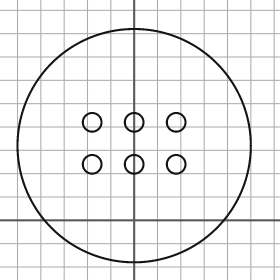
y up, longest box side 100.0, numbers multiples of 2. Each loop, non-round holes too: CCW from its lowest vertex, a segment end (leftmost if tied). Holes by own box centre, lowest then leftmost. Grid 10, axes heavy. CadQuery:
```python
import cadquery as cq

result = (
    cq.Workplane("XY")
    .moveTo(0.0, 32.0)
    .circle(50.0)
    .moveTo(-18.0, 24.0)
    .circle(4.0)
    .moveTo(0.0, 24.0)
    .circle(4.0)
    .moveTo(18.0, 24.0)
    .circle(4.0)
    .moveTo(-18.0, 42.0)
    .circle(4.0)
    .moveTo(0.0, 42.0)
    .circle(4.0)
    .moveTo(18.0, 42.0)
    .circle(4.0)
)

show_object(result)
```